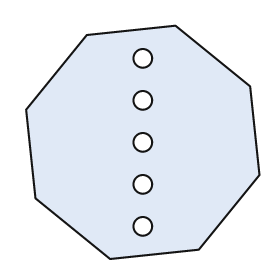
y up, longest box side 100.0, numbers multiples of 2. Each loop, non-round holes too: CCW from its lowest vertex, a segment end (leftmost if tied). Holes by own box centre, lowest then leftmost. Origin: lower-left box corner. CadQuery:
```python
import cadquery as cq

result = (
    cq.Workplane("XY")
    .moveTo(36.0, 0.0)
    .lineTo(74.0, 4.0)
    .lineTo(100.0, 36.0)
    .lineTo(96.0, 74.0)
    .lineTo(64.0, 100.0)
    .lineTo(26.0, 96.0)
    .lineTo(0.0, 64.0)
    .lineTo(4.0, 26.0)
    .close()
    .moveTo(50.0, 14.0)
    .circle(4.0)
    .moveTo(50.0, 32.0)
    .circle(4.0)
    .moveTo(50.0, 50.0)
    .circle(4.0)
    .moveTo(50.0, 68.0)
    .circle(4.0)
    .moveTo(50.0, 86.0)
    .circle(4.0)
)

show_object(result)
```